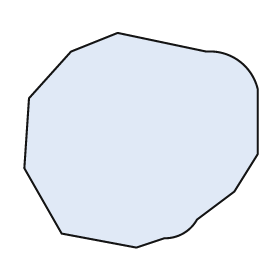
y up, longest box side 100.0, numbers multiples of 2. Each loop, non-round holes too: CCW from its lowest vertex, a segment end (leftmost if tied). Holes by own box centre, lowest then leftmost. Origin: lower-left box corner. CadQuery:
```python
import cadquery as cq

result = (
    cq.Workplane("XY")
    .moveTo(48.0, 0.0)
    .lineTo(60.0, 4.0)
    .threePointArc((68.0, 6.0), (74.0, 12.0))
    .lineTo(90.0, 24.0)
    .lineTo(100.0, 40.0)
    .lineTo(100.0, 68.0)
    .threePointArc((92.0, 80.0), (78.0, 84.0))
    .lineTo(40.0, 92.0)
    .lineTo(20.0, 84.0)
    .lineTo(2.0, 64.0)
    .lineTo(0.0, 34.0)
    .lineTo(16.0, 6.0)
    .close()
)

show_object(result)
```